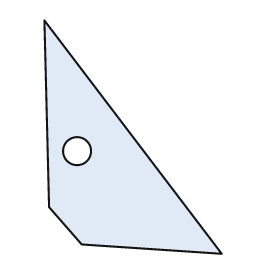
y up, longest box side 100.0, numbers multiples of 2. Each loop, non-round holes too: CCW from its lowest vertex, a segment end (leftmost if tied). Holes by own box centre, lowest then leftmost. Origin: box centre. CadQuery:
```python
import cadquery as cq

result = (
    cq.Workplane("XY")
    .moveTo(38.0, -50.0)
    .lineTo(-38.0, 50.0)
    .lineTo(-36.0, -30.0)
    .lineTo(-22.0, -46.0)
    .close()
    .moveTo(-24.0, -6.0)
    .circle(6.0)
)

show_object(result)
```